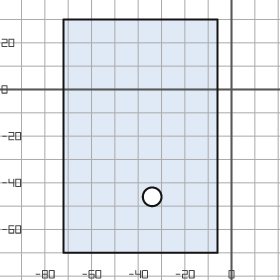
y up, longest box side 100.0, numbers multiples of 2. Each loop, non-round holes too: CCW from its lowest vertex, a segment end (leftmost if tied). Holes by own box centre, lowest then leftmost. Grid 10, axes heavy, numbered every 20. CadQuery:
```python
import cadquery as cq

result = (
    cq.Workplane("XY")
    .moveTo(-72.0, -70.0)
    .lineTo(-6.0, -70.0)
    .lineTo(-6.0, 30.0)
    .lineTo(-72.0, 30.0)
    .close()
    .moveTo(-34.0, -46.0)
    .circle(4.0)
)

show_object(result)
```